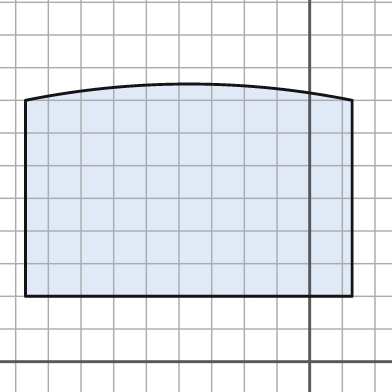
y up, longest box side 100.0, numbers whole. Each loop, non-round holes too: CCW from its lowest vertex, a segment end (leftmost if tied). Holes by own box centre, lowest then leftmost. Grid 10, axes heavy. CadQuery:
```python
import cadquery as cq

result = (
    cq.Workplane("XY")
    .moveTo(-87.0, 20.0)
    .lineTo(13.0, 20.0)
    .lineTo(13.0, 80.0)
    .threePointArc((-37.0, 85.0), (-87.0, 80.0))
    .close()
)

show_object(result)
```